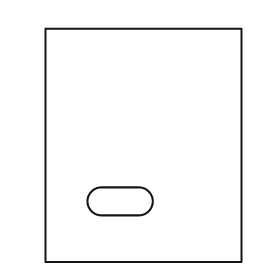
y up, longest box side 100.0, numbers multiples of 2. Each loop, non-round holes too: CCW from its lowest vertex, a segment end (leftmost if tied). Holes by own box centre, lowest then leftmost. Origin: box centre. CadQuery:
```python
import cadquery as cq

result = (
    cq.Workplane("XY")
    .moveTo(-42.0, -50.0)
    .lineTo(42.0, -50.0)
    .lineTo(42.0, 50.0)
    .lineTo(-42.0, 50.0)
    .close()
    .moveTo(-18.0, -30.0)
    .lineTo(-2.0, -30.0)
    .threePointArc((4.0, -24.0), (-2.0, -18.0))
    .lineTo(-18.0, -18.0)
    .threePointArc((-24.0, -24.0), (-18.0, -30.0))
    .close()
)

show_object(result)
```